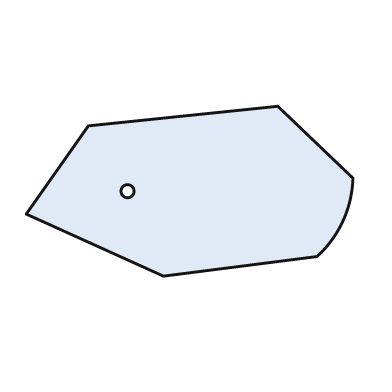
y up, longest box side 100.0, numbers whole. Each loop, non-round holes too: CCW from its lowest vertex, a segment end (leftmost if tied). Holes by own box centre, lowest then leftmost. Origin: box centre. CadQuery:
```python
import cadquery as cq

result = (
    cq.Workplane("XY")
    .moveTo(-8.0, -26.0)
    .lineTo(39.0, -20.0)
    .threePointArc((47.0, -9.0), (50.0, 4.0))
    .lineTo(27.0, 26.0)
    .lineTo(-31.0, 20.0)
    .lineTo(-50.0, -7.0)
    .close()
    .moveTo(-19.0, 0.0)
    .circle(2.0)
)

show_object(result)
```